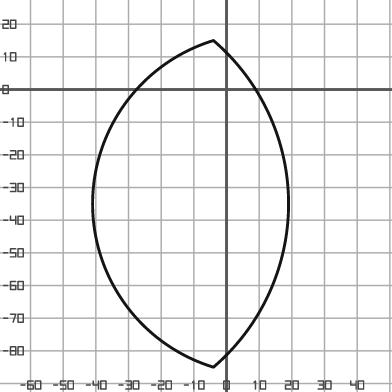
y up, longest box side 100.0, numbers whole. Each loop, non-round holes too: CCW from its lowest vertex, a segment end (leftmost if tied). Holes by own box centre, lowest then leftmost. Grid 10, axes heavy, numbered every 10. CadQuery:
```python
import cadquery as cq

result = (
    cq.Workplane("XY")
    .moveTo(-4.0, -85.0)
    .threePointArc((19.0, -35.0), (-4.0, 15.0))
    .threePointArc((-41.0, -35.0), (-4.0, -85.0))
    .close()
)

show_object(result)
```